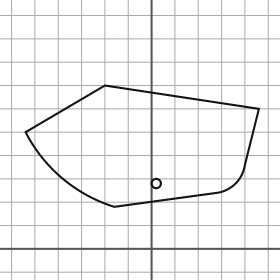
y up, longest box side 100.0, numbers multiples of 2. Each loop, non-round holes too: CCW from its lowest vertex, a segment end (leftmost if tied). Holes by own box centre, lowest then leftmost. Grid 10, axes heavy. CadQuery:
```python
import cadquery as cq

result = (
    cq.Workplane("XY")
    .moveTo(-16.0, 18.0)
    .lineTo(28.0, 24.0)
    .threePointArc((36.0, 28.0), (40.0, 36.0))
    .lineTo(46.0, 60.0)
    .lineTo(-20.0, 70.0)
    .lineTo(-54.0, 50.0)
    .threePointArc((-38.0, 30.0), (-16.0, 18.0))
    .close()
    .moveTo(2.0, 28.0)
    .circle(2.0)
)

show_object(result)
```